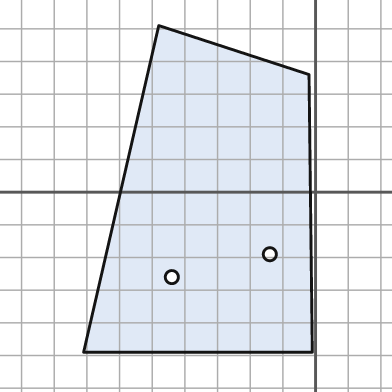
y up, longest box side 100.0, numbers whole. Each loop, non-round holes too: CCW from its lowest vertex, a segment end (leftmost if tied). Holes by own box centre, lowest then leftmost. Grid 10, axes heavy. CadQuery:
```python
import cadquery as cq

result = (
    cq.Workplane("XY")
    .moveTo(-71.0, -49.0)
    .lineTo(-1.0, -49.0)
    .lineTo(-2.0, 36.0)
    .lineTo(-48.0, 51.0)
    .close()
    .moveTo(-44.0, -26.0)
    .circle(2.0)
    .moveTo(-14.0, -19.0)
    .circle(2.0)
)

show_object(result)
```